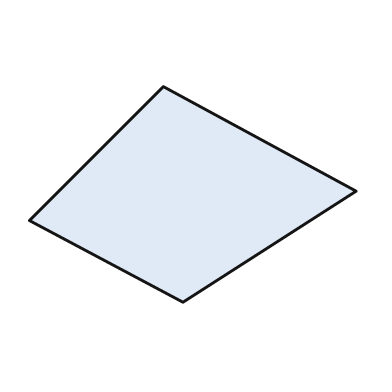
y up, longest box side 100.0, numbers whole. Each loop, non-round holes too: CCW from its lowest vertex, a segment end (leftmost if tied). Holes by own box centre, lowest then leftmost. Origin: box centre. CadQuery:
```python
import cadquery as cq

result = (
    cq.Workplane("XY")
    .moveTo(-3.0, -33.0)
    .lineTo(50.0, 1.0)
    .lineTo(-9.0, 33.0)
    .lineTo(-50.0, -8.0)
    .close()
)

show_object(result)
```